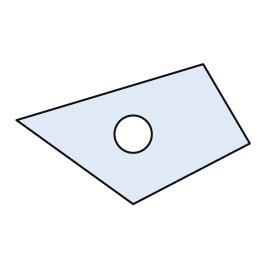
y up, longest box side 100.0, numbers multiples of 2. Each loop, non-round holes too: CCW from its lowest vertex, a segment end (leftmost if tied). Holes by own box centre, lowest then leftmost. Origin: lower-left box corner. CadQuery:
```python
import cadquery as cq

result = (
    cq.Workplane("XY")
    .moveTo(50.0, 0.0)
    .lineTo(100.0, 26.0)
    .lineTo(80.0, 60.0)
    .lineTo(0.0, 36.0)
    .close()
    .moveTo(50.0, 30.0)
    .circle(8.0)
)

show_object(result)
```